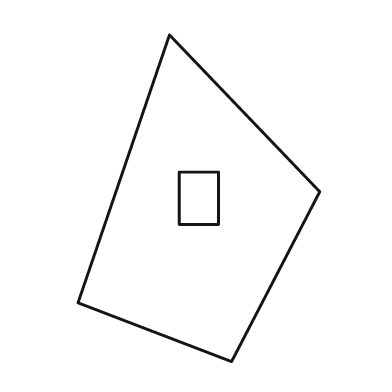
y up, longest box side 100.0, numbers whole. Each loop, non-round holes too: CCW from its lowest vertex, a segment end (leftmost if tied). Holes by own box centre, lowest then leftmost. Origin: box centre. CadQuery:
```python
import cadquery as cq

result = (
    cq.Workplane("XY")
    .moveTo(10.0, -50.0)
    .lineTo(37.0, 2.0)
    .lineTo(-9.0, 50.0)
    .lineTo(-37.0, -32.0)
    .close()
    .moveTo(-6.0, -8.0)
    .lineTo(6.0, -8.0)
    .lineTo(6.0, 8.0)
    .lineTo(-6.0, 8.0)
    .close()
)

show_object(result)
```